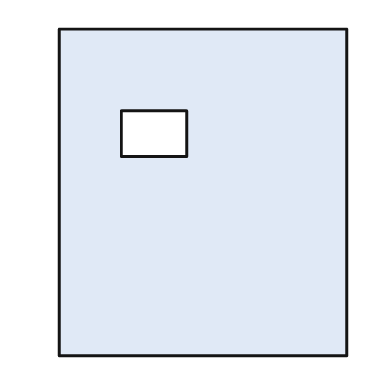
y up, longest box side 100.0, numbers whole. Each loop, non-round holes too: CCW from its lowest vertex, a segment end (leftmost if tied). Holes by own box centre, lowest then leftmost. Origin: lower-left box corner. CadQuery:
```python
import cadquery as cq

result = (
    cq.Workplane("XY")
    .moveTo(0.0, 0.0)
    .lineTo(88.0, 0.0)
    .lineTo(88.0, 100.0)
    .lineTo(0.0, 100.0)
    .close()
    .moveTo(19.0, 61.0)
    .lineTo(39.0, 61.0)
    .lineTo(39.0, 75.0)
    .lineTo(19.0, 75.0)
    .close()
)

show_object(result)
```